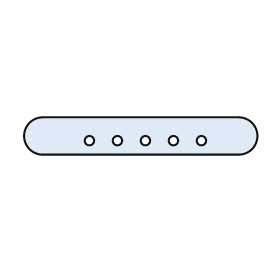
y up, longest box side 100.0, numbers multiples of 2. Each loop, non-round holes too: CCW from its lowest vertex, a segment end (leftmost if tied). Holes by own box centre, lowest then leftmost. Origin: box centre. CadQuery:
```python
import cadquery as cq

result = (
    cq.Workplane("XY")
    .moveTo(-42.0, -8.0)
    .lineTo(42.0, -8.0)
    .threePointArc((50.0, 0.0), (42.0, 8.0))
    .lineTo(-42.0, 8.0)
    .threePointArc((-50.0, 0.0), (-42.0, -8.0))
    .close()
    .moveTo(-22.0, -2.0)
    .circle(2.0)
    .moveTo(-10.0, -2.0)
    .circle(2.0)
    .moveTo(2.0, -2.0)
    .circle(2.0)
    .moveTo(14.0, -2.0)
    .circle(2.0)
    .moveTo(26.0, -2.0)
    .circle(2.0)
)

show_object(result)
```